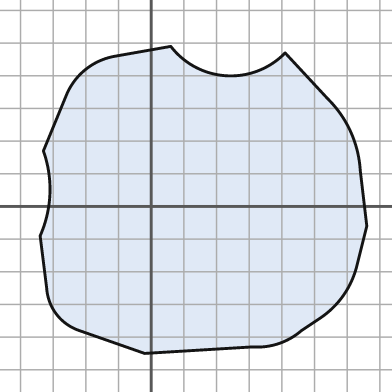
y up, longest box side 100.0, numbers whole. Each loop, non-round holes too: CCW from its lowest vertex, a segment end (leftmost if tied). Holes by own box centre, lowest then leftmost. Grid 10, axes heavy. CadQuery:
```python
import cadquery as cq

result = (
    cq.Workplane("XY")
    .moveTo(-2.0, -45.0)
    .lineTo(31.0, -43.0)
    .threePointArc((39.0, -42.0), (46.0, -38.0))
    .lineTo(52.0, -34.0)
    .threePointArc((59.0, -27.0), (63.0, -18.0))
    .lineTo(66.0, -6.0)
    .lineTo(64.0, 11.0)
    .threePointArc((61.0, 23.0), (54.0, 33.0))
    .lineTo(41.0, 47.0)
    .threePointArc((23.0, 40.0), (6.0, 49.0))
    .lineTo(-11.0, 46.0)
    .threePointArc((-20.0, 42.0), (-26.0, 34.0))
    .lineTo(-33.0, 17.0)
    .threePointArc((-31.0, 4.0), (-34.0, -9.0))
    .lineTo(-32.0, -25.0)
    .threePointArc((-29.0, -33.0), (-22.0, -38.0))
    .close()
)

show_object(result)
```